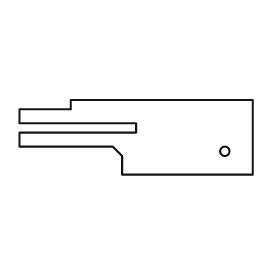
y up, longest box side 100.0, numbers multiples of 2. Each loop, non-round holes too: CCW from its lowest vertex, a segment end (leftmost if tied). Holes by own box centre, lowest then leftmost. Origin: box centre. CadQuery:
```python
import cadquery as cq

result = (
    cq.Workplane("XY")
    .moveTo(-6.0, -16.0)
    .lineTo(50.0, -16.0)
    .lineTo(50.0, 16.0)
    .lineTo(-28.0, 16.0)
    .lineTo(-28.0, 12.0)
    .lineTo(-50.0, 12.0)
    .lineTo(-50.0, 6.0)
    .lineTo(0.0, 6.0)
    .lineTo(0.0, 2.0)
    .lineTo(-50.0, 2.0)
    .lineTo(-50.0, -4.0)
    .lineTo(-10.0, -4.0)
    .lineTo(-6.0, -8.0)
    .close()
    .moveTo(38.0, -6.0)
    .circle(2.0)
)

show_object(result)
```